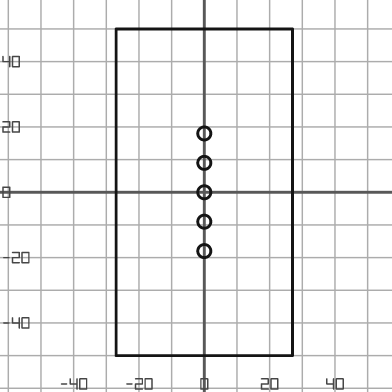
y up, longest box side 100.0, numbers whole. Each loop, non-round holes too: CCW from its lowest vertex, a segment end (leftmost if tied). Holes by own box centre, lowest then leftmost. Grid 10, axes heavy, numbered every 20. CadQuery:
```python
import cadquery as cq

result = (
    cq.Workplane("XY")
    .moveTo(-27.0, -50.0)
    .lineTo(27.0, -50.0)
    .lineTo(27.0, 50.0)
    .lineTo(-27.0, 50.0)
    .close()
    .moveTo(0.0, -18.0)
    .circle(2.0)
    .moveTo(0.0, -9.0)
    .circle(2.0)
    .moveTo(0.0, 0.0)
    .circle(2.0)
    .moveTo(0.0, 9.0)
    .circle(2.0)
    .moveTo(0.0, 18.0)
    .circle(2.0)
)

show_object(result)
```